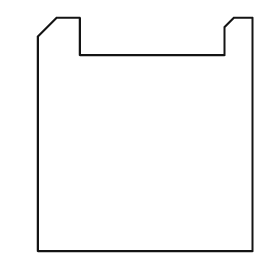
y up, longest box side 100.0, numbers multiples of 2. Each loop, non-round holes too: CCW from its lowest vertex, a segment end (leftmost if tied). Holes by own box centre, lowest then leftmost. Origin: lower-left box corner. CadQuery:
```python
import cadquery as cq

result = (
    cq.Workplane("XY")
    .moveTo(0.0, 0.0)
    .lineTo(92.0, 0.0)
    .lineTo(92.0, 100.0)
    .lineTo(84.0, 100.0)
    .lineTo(80.0, 96.0)
    .lineTo(80.0, 84.0)
    .lineTo(18.0, 84.0)
    .lineTo(18.0, 100.0)
    .lineTo(8.0, 100.0)
    .lineTo(0.0, 92.0)
    .close()
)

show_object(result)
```